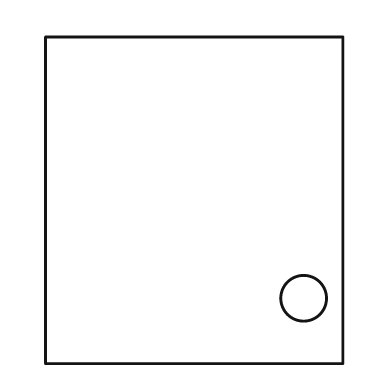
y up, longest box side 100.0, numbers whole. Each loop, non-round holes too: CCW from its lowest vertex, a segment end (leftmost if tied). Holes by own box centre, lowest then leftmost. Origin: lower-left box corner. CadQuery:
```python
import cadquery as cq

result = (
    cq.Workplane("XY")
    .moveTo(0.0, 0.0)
    .lineTo(91.0, 0.0)
    .lineTo(91.0, 100.0)
    .lineTo(0.0, 100.0)
    .close()
    .moveTo(79.0, 20.0)
    .circle(7.0)
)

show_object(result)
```